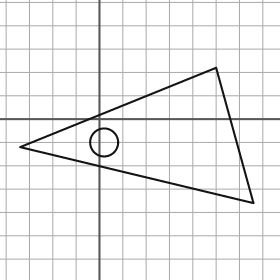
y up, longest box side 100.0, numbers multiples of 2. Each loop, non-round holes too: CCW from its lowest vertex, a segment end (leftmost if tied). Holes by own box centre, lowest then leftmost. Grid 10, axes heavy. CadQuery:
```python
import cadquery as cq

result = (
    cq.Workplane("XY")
    .moveTo(66.0, -36.0)
    .lineTo(50.0, 22.0)
    .lineTo(-34.0, -12.0)
    .close()
    .moveTo(2.0, -10.0)
    .circle(6.0)
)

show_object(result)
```